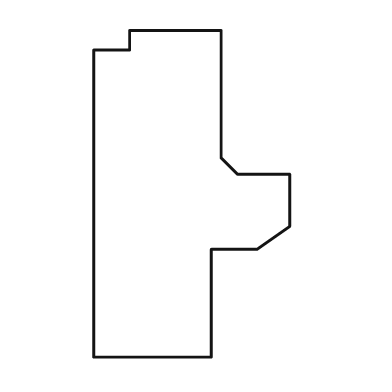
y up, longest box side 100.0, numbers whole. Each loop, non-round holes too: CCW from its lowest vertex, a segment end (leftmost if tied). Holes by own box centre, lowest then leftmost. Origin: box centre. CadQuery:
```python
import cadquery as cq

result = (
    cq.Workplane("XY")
    .moveTo(-30.0, -50.0)
    .lineTo(6.0, -50.0)
    .lineTo(6.0, -17.0)
    .lineTo(20.0, -17.0)
    .lineTo(30.0, -10.0)
    .lineTo(30.0, 6.0)
    .lineTo(14.0, 6.0)
    .lineTo(9.0, 11.0)
    .lineTo(9.0, 50.0)
    .lineTo(-19.0, 50.0)
    .lineTo(-19.0, 44.0)
    .lineTo(-30.0, 44.0)
    .close()
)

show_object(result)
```